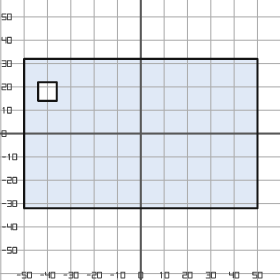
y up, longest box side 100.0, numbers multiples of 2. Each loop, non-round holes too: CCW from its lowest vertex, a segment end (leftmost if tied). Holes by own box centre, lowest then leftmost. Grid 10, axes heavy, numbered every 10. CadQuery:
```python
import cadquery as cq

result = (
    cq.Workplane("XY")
    .moveTo(-50.0, -32.0)
    .lineTo(50.0, -32.0)
    .lineTo(50.0, 32.0)
    .lineTo(-50.0, 32.0)
    .close()
    .moveTo(-44.0, 14.0)
    .lineTo(-36.0, 14.0)
    .lineTo(-36.0, 22.0)
    .lineTo(-44.0, 22.0)
    .close()
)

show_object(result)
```